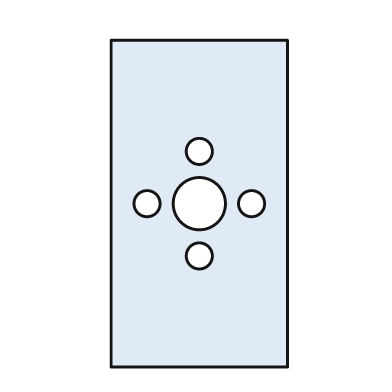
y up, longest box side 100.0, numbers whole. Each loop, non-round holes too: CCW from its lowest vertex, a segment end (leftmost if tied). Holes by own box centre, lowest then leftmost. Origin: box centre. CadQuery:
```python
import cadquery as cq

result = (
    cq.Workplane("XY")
    .moveTo(-27.0, -50.0)
    .lineTo(27.0, -50.0)
    .lineTo(27.0, 50.0)
    .lineTo(-27.0, 50.0)
    .close()
    .moveTo(0.0, -16.0)
    .circle(4.0)
    .moveTo(-16.0, 0.0)
    .circle(4.0)
    .moveTo(0.0, 0.0)
    .circle(8.0)
    .moveTo(16.0, 0.0)
    .circle(4.0)
    .moveTo(0.0, 16.0)
    .circle(4.0)
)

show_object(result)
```